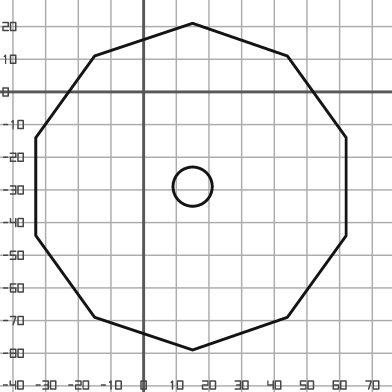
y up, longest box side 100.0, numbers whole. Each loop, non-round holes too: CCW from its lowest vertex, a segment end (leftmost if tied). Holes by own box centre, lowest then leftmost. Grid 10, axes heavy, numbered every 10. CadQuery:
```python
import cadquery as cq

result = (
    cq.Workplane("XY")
    .moveTo(15.0, -79.0)
    .lineTo(44.0, -69.0)
    .lineTo(62.0, -44.0)
    .lineTo(62.0, -14.0)
    .lineTo(44.0, 11.0)
    .lineTo(15.0, 21.0)
    .lineTo(-15.0, 11.0)
    .lineTo(-33.0, -14.0)
    .lineTo(-33.0, -44.0)
    .lineTo(-15.0, -69.0)
    .close()
    .moveTo(15.0, -29.0)
    .circle(6.0)
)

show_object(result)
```